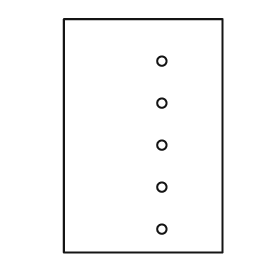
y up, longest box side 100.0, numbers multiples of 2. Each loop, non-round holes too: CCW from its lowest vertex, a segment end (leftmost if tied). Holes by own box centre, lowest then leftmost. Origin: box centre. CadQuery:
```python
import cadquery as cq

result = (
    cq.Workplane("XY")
    .moveTo(-34.0, -50.0)
    .lineTo(34.0, -50.0)
    .lineTo(34.0, 50.0)
    .lineTo(-34.0, 50.0)
    .close()
    .moveTo(8.0, -40.0)
    .circle(2.0)
    .moveTo(8.0, -22.0)
    .circle(2.0)
    .moveTo(8.0, -4.0)
    .circle(2.0)
    .moveTo(8.0, 14.0)
    .circle(2.0)
    .moveTo(8.0, 32.0)
    .circle(2.0)
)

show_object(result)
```